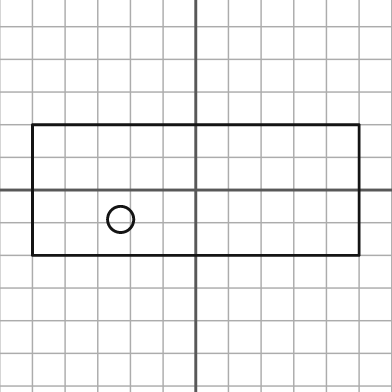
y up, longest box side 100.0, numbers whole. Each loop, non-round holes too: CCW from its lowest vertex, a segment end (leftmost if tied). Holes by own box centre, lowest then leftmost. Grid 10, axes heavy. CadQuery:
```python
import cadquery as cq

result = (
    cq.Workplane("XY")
    .moveTo(-50.0, -20.0)
    .lineTo(50.0, -20.0)
    .lineTo(50.0, 20.0)
    .lineTo(-50.0, 20.0)
    .close()
    .moveTo(-23.0, -9.0)
    .circle(4.0)
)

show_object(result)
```